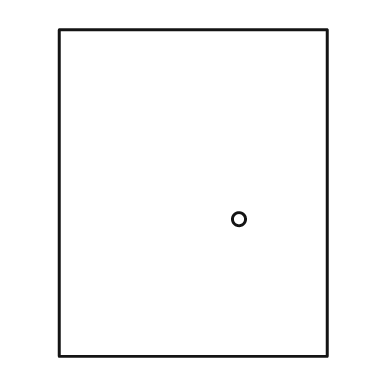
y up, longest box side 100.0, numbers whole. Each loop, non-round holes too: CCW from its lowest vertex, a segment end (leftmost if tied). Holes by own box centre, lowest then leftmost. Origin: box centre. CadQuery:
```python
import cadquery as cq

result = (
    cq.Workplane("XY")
    .moveTo(-41.0, -50.0)
    .lineTo(41.0, -50.0)
    .lineTo(41.0, 50.0)
    .lineTo(-41.0, 50.0)
    .close()
    .moveTo(14.0, -8.0)
    .circle(2.0)
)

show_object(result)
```